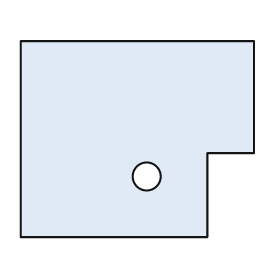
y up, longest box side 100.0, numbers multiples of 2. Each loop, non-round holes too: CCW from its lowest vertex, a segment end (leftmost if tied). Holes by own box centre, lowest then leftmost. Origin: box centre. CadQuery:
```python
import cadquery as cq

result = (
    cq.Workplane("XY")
    .moveTo(-50.0, -42.0)
    .lineTo(30.0, -42.0)
    .lineTo(30.0, -6.0)
    .lineTo(50.0, -6.0)
    .lineTo(50.0, 42.0)
    .lineTo(-50.0, 42.0)
    .close()
    .moveTo(4.0, -16.0)
    .circle(6.0)
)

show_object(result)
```